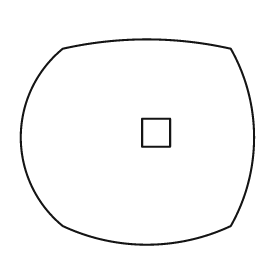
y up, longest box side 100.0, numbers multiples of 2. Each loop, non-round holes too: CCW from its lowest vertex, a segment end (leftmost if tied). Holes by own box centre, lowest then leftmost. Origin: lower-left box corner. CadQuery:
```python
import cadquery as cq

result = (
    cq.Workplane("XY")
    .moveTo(18.0, 8.0)
    .threePointArc((54.0, 0.0), (90.0, 8.0))
    .threePointArc((100.0, 46.0), (90.0, 84.0))
    .threePointArc((54.0, 88.0), (18.0, 84.0))
    .threePointArc((0.0, 46.0), (18.0, 8.0))
    .close()
    .moveTo(52.0, 42.0)
    .lineTo(64.0, 42.0)
    .lineTo(64.0, 54.0)
    .lineTo(52.0, 54.0)
    .close()
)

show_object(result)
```